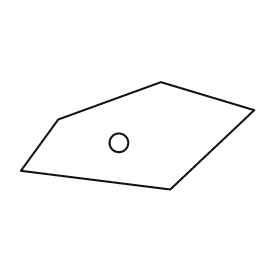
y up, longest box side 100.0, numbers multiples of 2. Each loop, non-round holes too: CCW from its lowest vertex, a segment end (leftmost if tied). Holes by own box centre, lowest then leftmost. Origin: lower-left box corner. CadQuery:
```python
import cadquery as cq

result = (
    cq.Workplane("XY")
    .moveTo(64.0, 0.0)
    .lineTo(100.0, 34.0)
    .lineTo(60.0, 46.0)
    .lineTo(16.0, 30.0)
    .lineTo(0.0, 8.0)
    .close()
    .moveTo(42.0, 20.0)
    .circle(4.0)
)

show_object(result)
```